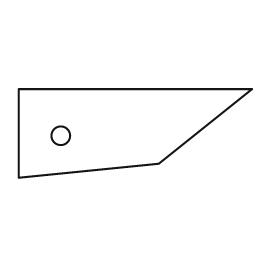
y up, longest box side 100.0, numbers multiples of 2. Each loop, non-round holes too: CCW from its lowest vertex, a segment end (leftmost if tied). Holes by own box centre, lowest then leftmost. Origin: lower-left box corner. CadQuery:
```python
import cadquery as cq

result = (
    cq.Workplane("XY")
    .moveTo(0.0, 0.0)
    .lineTo(60.0, 6.0)
    .lineTo(100.0, 38.0)
    .lineTo(0.0, 38.0)
    .close()
    .moveTo(18.0, 18.0)
    .circle(4.0)
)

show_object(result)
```